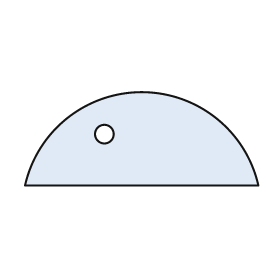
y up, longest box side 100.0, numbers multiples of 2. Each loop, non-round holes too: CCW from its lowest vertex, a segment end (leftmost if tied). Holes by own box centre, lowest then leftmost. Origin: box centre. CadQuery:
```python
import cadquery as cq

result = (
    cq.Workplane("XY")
    .moveTo(-50.0, -20.0)
    .lineTo(50.0, -20.0)
    .threePointArc((0.0, 20.0), (-50.0, -20.0))
    .close()
    .moveTo(-16.0, 2.0)
    .circle(4.0)
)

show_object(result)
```